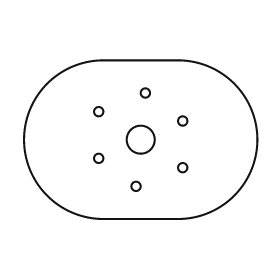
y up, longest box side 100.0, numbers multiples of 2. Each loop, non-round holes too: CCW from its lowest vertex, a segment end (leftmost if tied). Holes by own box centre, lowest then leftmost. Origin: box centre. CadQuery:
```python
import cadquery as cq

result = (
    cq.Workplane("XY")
    .moveTo(-16.0, -34.0)
    .lineTo(16.0, -34.0)
    .threePointArc((50.0, 0.0), (16.0, 34.0))
    .lineTo(-16.0, 34.0)
    .threePointArc((-50.0, 0.0), (-16.0, -34.0))
    .close()
    .moveTo(-2.0, -20.0)
    .circle(2.0)
    .moveTo(18.0, -12.0)
    .circle(2.0)
    .moveTo(-18.0, -8.0)
    .circle(2.0)
    .moveTo(0.0, 0.0)
    .circle(6.0)
    .moveTo(18.0, 8.0)
    .circle(2.0)
    .moveTo(-18.0, 12.0)
    .circle(2.0)
    .moveTo(2.0, 20.0)
    .circle(2.0)
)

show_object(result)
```